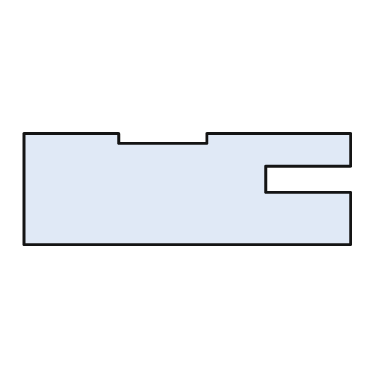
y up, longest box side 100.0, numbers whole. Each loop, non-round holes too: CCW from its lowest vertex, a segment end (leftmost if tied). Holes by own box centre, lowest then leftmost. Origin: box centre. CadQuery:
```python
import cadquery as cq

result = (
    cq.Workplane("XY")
    .moveTo(-50.0, -17.0)
    .lineTo(50.0, -17.0)
    .lineTo(50.0, -1.0)
    .lineTo(24.0, -1.0)
    .lineTo(24.0, 7.0)
    .lineTo(50.0, 7.0)
    .lineTo(50.0, 17.0)
    .lineTo(6.0, 17.0)
    .lineTo(6.0, 14.0)
    .lineTo(-21.0, 14.0)
    .lineTo(-21.0, 17.0)
    .lineTo(-50.0, 17.0)
    .close()
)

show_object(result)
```